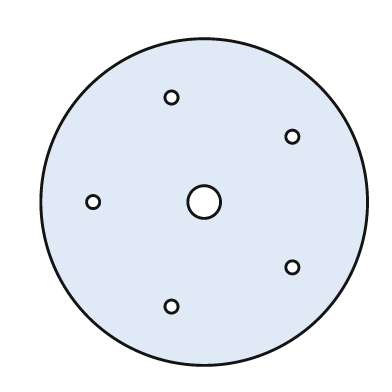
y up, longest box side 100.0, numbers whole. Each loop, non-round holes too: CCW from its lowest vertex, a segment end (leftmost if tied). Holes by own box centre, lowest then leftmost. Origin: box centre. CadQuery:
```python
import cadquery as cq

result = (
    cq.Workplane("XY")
    .moveTo(0.0, 0.0)
    .circle(50.0)
    .moveTo(-10.0, -32.0)
    .circle(2.0)
    .moveTo(27.0, -20.0)
    .circle(2.0)
    .moveTo(-34.0, 0.0)
    .circle(2.0)
    .moveTo(0.0, 0.0)
    .circle(5.0)
    .moveTo(27.0, 20.0)
    .circle(2.0)
    .moveTo(-10.0, 32.0)
    .circle(2.0)
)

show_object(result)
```